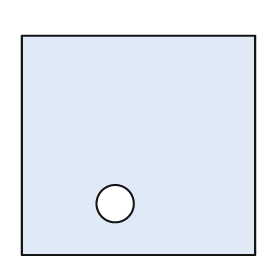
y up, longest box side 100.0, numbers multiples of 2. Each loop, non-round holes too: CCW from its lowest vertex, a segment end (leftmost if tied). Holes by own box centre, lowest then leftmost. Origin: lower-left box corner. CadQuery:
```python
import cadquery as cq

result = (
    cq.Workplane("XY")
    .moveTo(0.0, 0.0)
    .lineTo(100.0, 0.0)
    .lineTo(100.0, 94.0)
    .lineTo(0.0, 94.0)
    .close()
    .moveTo(40.0, 22.0)
    .circle(8.0)
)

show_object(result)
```